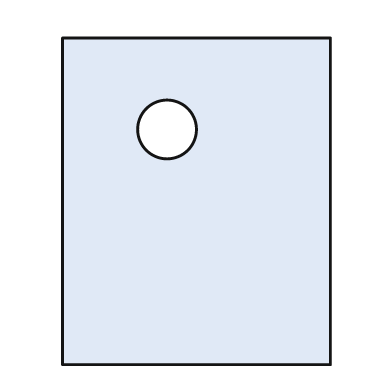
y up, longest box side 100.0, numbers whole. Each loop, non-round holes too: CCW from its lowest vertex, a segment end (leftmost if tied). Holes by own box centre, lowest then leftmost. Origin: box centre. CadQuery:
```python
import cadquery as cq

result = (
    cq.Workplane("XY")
    .moveTo(-41.0, -50.0)
    .lineTo(41.0, -50.0)
    .lineTo(41.0, 50.0)
    .lineTo(-41.0, 50.0)
    .close()
    .moveTo(-9.0, 22.0)
    .circle(9.0)
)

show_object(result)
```